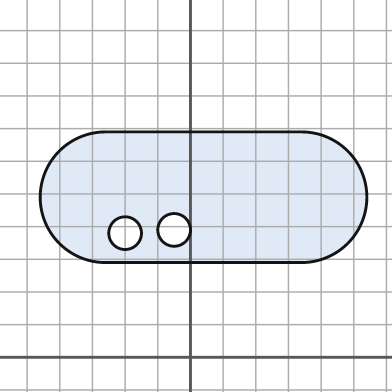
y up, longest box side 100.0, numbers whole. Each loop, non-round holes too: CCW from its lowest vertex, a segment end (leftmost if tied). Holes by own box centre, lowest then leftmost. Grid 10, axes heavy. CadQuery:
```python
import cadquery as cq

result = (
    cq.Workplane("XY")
    .moveTo(-26.0, 29.0)
    .lineTo(34.0, 29.0)
    .threePointArc((54.0, 49.0), (34.0, 69.0))
    .lineTo(-26.0, 69.0)
    .threePointArc((-46.0, 49.0), (-26.0, 29.0))
    .close()
    .moveTo(-20.0, 38.0)
    .circle(5.0)
    .moveTo(-5.0, 39.0)
    .circle(5.0)
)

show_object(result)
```